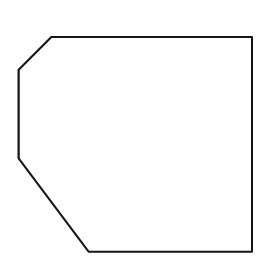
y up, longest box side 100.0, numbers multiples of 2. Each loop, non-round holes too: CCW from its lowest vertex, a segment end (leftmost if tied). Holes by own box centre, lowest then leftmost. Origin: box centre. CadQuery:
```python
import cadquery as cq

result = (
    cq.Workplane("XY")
    .moveTo(-20.0, -46.0)
    .lineTo(50.0, -46.0)
    .lineTo(50.0, 46.0)
    .lineTo(-36.0, 46.0)
    .lineTo(-50.0, 32.0)
    .lineTo(-50.0, -6.0)
    .close()
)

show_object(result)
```